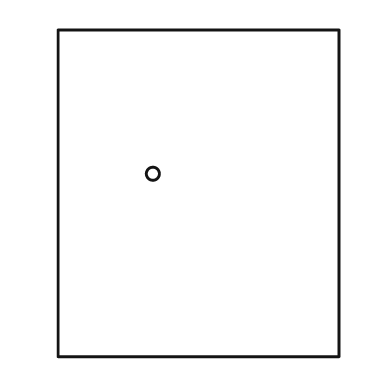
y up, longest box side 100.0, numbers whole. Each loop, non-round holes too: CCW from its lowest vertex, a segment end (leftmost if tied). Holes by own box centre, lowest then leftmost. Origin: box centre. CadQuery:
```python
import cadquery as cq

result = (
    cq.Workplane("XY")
    .moveTo(-43.0, -50.0)
    .lineTo(43.0, -50.0)
    .lineTo(43.0, 50.0)
    .lineTo(-43.0, 50.0)
    .close()
    .moveTo(-14.0, 6.0)
    .circle(2.0)
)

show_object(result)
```